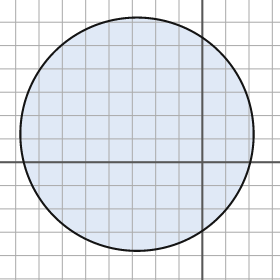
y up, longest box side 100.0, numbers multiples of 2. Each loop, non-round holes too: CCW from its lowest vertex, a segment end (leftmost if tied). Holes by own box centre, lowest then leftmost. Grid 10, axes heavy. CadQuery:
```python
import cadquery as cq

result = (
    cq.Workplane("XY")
    .moveTo(-28.0, 12.0)
    .circle(50.0)
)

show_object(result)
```